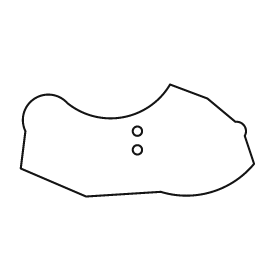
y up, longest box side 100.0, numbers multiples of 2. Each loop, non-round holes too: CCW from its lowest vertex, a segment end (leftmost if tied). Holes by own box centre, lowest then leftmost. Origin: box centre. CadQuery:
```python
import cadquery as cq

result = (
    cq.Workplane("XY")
    .moveTo(-22.0, -24.0)
    .lineTo(10.0, -22.0)
    .threePointArc((32.0, -22.0), (50.0, -10.0))
    .lineTo(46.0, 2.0)
    .threePointArc((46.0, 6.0), (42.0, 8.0))
    .lineTo(30.0, 18.0)
    .lineTo(14.0, 24.0)
    .threePointArc((-6.0, 10.0), (-30.0, 16.0))
    .threePointArc((-44.0, 18.0), (-48.0, 4.0))
    .lineTo(-50.0, -12.0)
    .close()
    .moveTo(0.0, -4.0)
    .circle(2.0)
    .moveTo(0.0, 4.0)
    .circle(2.0)
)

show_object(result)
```